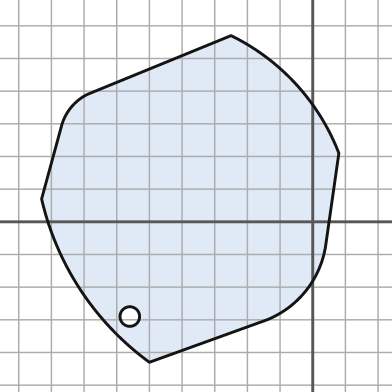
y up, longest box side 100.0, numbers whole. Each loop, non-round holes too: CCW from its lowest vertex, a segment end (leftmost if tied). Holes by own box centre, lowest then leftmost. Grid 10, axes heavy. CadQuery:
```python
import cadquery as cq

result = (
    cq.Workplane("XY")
    .moveTo(-50.0, -43.0)
    .lineTo(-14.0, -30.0)
    .threePointArc((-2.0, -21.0), (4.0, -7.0))
    .lineTo(8.0, 21.0)
    .threePointArc((-5.0, 42.0), (-25.0, 57.0))
    .lineTo(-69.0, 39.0)
    .threePointArc((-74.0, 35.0), (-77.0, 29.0))
    .lineTo(-83.0, 7.0)
    .threePointArc((-71.0, -21.0), (-50.0, -43.0))
    .close()
    .moveTo(-56.0, -29.0)
    .circle(3.0)
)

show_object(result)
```